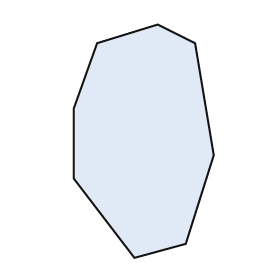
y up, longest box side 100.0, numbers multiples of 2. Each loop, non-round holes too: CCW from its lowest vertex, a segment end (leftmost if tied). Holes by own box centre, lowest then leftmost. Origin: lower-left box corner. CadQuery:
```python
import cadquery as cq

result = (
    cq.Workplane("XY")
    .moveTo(26.0, 0.0)
    .lineTo(48.0, 6.0)
    .lineTo(60.0, 44.0)
    .lineTo(52.0, 92.0)
    .lineTo(36.0, 100.0)
    .lineTo(10.0, 92.0)
    .lineTo(0.0, 64.0)
    .lineTo(0.0, 34.0)
    .close()
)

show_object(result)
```